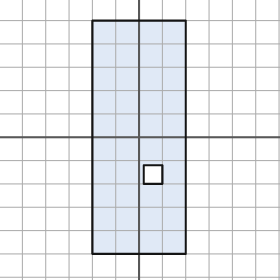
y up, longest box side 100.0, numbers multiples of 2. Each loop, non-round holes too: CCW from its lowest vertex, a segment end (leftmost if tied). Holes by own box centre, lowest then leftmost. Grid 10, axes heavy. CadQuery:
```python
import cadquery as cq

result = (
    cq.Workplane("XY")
    .moveTo(-20.0, -50.0)
    .lineTo(20.0, -50.0)
    .lineTo(20.0, 50.0)
    .lineTo(-20.0, 50.0)
    .close()
    .moveTo(2.0, -20.0)
    .lineTo(10.0, -20.0)
    .lineTo(10.0, -12.0)
    .lineTo(2.0, -12.0)
    .close()
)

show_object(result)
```